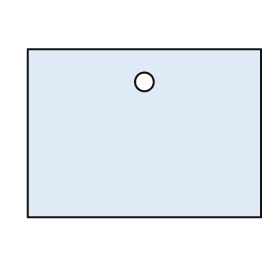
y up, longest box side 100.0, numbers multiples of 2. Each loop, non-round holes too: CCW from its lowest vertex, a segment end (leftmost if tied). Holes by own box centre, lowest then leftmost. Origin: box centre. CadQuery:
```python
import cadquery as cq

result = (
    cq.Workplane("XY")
    .moveTo(-50.0, -36.0)
    .lineTo(50.0, -36.0)
    .lineTo(50.0, 36.0)
    .lineTo(-50.0, 36.0)
    .close()
    .moveTo(0.0, 22.0)
    .circle(4.0)
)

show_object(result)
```